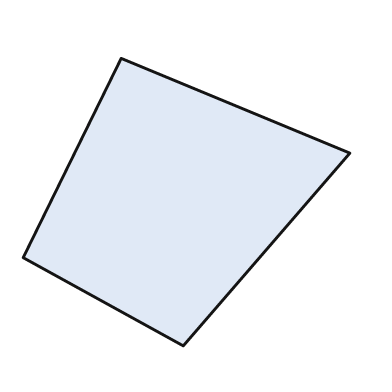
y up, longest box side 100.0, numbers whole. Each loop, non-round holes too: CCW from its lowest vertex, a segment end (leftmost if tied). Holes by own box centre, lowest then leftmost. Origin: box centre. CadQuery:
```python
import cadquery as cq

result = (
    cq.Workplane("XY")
    .moveTo(-1.0, -44.0)
    .lineTo(50.0, 15.0)
    .lineTo(-20.0, 44.0)
    .lineTo(-50.0, -17.0)
    .close()
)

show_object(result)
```